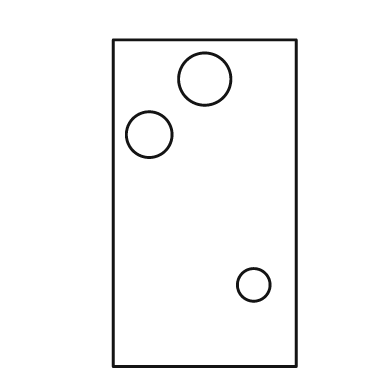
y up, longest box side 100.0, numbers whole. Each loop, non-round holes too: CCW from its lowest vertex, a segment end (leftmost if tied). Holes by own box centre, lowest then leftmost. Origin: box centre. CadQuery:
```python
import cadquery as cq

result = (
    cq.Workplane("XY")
    .moveTo(-28.0, -50.0)
    .lineTo(28.0, -50.0)
    .lineTo(28.0, 50.0)
    .lineTo(-28.0, 50.0)
    .close()
    .moveTo(15.0, -25.0)
    .circle(5.0)
    .moveTo(-17.0, 21.0)
    .circle(7.0)
    .moveTo(0.0, 38.0)
    .circle(8.0)
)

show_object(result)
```